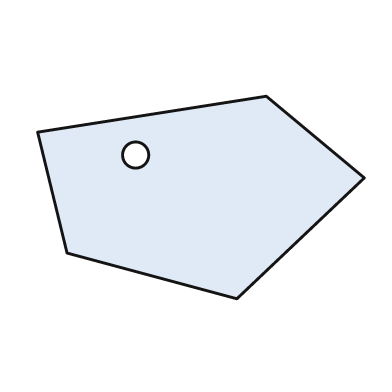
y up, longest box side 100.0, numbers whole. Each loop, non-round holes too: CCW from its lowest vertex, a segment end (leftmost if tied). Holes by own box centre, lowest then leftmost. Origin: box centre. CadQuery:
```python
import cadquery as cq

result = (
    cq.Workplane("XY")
    .moveTo(11.0, -31.0)
    .lineTo(50.0, 6.0)
    .lineTo(20.0, 31.0)
    .lineTo(-50.0, 20.0)
    .lineTo(-41.0, -17.0)
    .close()
    .moveTo(-20.0, 13.0)
    .circle(4.0)
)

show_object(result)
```